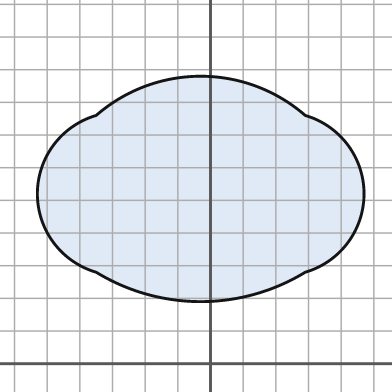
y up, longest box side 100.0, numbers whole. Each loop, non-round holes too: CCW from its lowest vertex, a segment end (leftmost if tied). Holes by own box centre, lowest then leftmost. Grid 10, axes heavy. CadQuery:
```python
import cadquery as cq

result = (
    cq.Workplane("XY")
    .moveTo(-35.0, 28.0)
    .threePointArc((-3.0, 19.0), (29.0, 28.0))
    .threePointArc((47.0, 52.0), (29.0, 76.0))
    .threePointArc((-3.0, 88.0), (-35.0, 76.0))
    .threePointArc((-53.0, 52.0), (-35.0, 28.0))
    .close()
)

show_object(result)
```